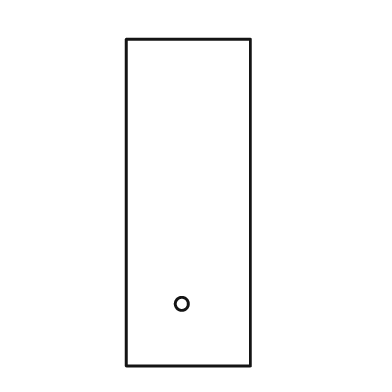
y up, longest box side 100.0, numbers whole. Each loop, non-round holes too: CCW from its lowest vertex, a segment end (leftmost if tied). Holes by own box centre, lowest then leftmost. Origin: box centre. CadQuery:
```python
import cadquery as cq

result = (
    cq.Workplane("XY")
    .moveTo(-19.0, -50.0)
    .lineTo(19.0, -50.0)
    .lineTo(19.0, 50.0)
    .lineTo(-19.0, 50.0)
    .close()
    .moveTo(-2.0, -31.0)
    .circle(2.0)
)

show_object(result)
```